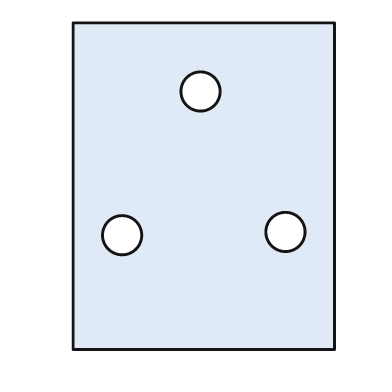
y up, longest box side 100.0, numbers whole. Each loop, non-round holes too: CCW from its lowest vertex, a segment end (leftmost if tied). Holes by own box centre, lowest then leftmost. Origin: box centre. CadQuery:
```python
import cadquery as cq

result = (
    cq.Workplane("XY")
    .moveTo(-40.0, -50.0)
    .lineTo(40.0, -50.0)
    .lineTo(40.0, 50.0)
    .lineTo(-40.0, 50.0)
    .close()
    .moveTo(-25.0, -15.0)
    .circle(6.0)
    .moveTo(25.0, -14.0)
    .circle(6.0)
    .moveTo(-1.0, 29.0)
    .circle(6.0)
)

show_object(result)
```